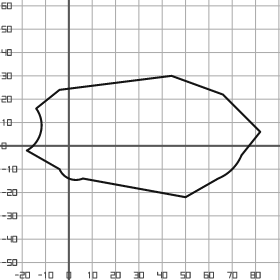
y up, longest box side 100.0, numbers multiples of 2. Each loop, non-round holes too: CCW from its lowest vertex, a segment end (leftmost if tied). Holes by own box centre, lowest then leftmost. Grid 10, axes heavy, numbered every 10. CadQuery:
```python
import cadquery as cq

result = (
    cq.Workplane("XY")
    .moveTo(50.0, -22.0)
    .lineTo(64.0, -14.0)
    .threePointArc((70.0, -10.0), (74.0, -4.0))
    .lineTo(82.0, 6.0)
    .lineTo(66.0, 22.0)
    .lineTo(44.0, 30.0)
    .lineTo(-4.0, 24.0)
    .lineTo(-14.0, 16.0)
    .threePointArc((-12.0, 6.0), (-18.0, -2.0))
    .lineTo(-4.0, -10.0)
    .threePointArc((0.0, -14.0), (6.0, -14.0))
    .close()
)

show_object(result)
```